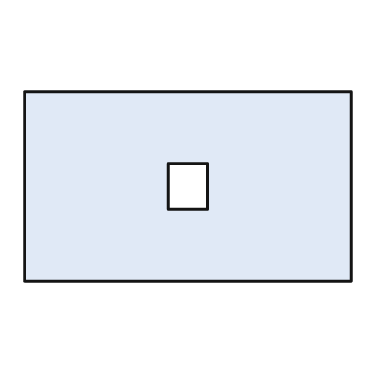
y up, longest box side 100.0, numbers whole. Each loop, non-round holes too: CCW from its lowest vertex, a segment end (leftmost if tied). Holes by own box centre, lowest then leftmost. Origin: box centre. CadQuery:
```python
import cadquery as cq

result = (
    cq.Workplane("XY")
    .moveTo(-50.0, -29.0)
    .lineTo(50.0, -29.0)
    .lineTo(50.0, 29.0)
    .lineTo(-50.0, 29.0)
    .close()
    .moveTo(-6.0, -7.0)
    .lineTo(6.0, -7.0)
    .lineTo(6.0, 7.0)
    .lineTo(-6.0, 7.0)
    .close()
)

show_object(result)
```